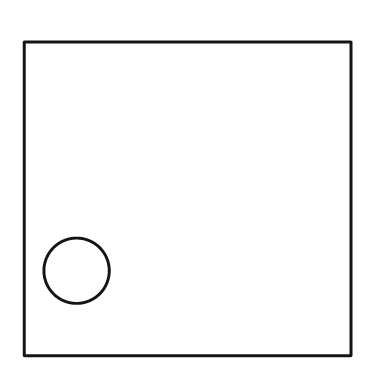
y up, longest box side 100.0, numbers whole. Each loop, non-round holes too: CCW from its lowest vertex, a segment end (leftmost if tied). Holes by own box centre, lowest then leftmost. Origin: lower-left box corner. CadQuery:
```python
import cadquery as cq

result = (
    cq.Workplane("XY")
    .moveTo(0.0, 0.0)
    .lineTo(100.0, 0.0)
    .lineTo(100.0, 96.0)
    .lineTo(0.0, 96.0)
    .close()
    .moveTo(16.0, 26.0)
    .circle(10.0)
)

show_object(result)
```